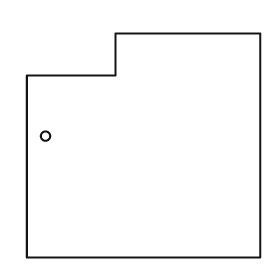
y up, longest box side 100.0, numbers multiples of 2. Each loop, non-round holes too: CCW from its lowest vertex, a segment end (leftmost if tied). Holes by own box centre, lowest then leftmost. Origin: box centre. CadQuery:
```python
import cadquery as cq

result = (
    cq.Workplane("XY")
    .moveTo(-50.0, -48.0)
    .lineTo(50.0, -48.0)
    .lineTo(50.0, 48.0)
    .lineTo(-12.0, 48.0)
    .lineTo(-12.0, 30.0)
    .lineTo(-50.0, 30.0)
    .close()
    .moveTo(-42.0, 4.0)
    .circle(2.0)
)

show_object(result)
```